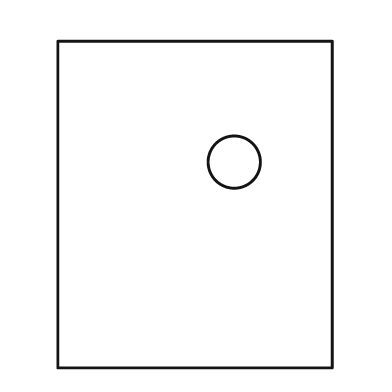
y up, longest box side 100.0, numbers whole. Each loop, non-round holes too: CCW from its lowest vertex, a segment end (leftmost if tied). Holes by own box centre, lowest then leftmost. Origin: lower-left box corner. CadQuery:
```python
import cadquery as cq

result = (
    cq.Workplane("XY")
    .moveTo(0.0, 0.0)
    .lineTo(84.0, 0.0)
    .lineTo(84.0, 100.0)
    .lineTo(0.0, 100.0)
    .close()
    .moveTo(54.0, 63.0)
    .circle(8.0)
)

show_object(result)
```